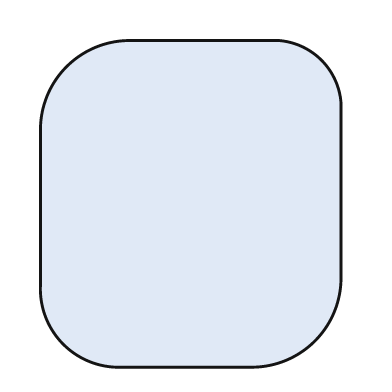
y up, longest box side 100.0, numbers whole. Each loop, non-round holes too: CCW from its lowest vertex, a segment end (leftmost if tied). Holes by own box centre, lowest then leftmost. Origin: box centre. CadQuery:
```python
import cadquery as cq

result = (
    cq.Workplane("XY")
    .moveTo(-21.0, -50.0)
    .lineTo(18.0, -50.0)
    .threePointArc((38.0, -42.0), (46.0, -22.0))
    .lineTo(46.0, 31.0)
    .threePointArc((40.0, 44.0), (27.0, 50.0))
    .lineTo(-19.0, 50.0)
    .threePointArc((-38.0, 42.0), (-46.0, 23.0))
    .lineTo(-46.0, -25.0)
    .threePointArc((-39.0, -43.0), (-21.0, -50.0))
    .close()
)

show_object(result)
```